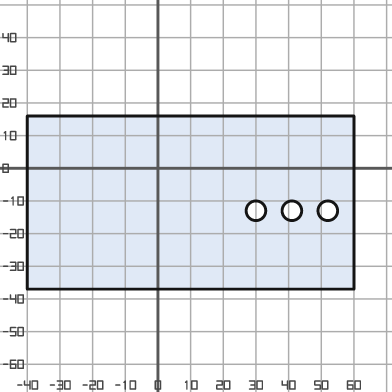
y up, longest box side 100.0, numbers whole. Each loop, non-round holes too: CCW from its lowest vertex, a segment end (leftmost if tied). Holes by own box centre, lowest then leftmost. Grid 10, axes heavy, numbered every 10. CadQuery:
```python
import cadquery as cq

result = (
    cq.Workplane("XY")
    .moveTo(-40.0, -37.0)
    .lineTo(60.0, -37.0)
    .lineTo(60.0, 16.0)
    .lineTo(-40.0, 16.0)
    .close()
    .moveTo(30.0, -13.0)
    .circle(3.0)
    .moveTo(41.0, -13.0)
    .circle(3.0)
    .moveTo(52.0, -13.0)
    .circle(3.0)
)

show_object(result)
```